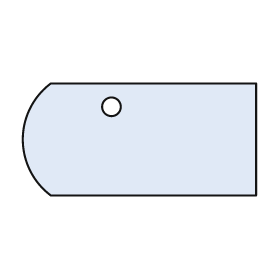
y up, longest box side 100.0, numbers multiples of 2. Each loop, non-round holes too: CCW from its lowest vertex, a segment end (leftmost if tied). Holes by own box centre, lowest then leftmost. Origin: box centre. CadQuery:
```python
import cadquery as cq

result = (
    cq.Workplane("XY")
    .moveTo(-38.0, -24.0)
    .lineTo(50.0, -24.0)
    .lineTo(50.0, 24.0)
    .lineTo(-38.0, 24.0)
    .threePointArc((-50.0, 0.0), (-38.0, -24.0))
    .close()
    .moveTo(-12.0, 14.0)
    .circle(4.0)
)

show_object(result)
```